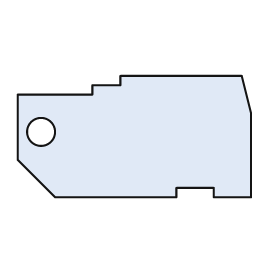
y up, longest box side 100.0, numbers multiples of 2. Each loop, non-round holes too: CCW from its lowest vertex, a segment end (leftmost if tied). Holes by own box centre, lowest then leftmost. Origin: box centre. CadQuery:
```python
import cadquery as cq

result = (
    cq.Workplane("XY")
    .moveTo(-34.0, -26.0)
    .lineTo(18.0, -26.0)
    .lineTo(18.0, -22.0)
    .lineTo(34.0, -22.0)
    .lineTo(34.0, -26.0)
    .lineTo(50.0, -26.0)
    .lineTo(50.0, 10.0)
    .lineTo(46.0, 26.0)
    .lineTo(-6.0, 26.0)
    .lineTo(-6.0, 22.0)
    .lineTo(-18.0, 22.0)
    .lineTo(-18.0, 18.0)
    .lineTo(-50.0, 18.0)
    .lineTo(-50.0, -10.0)
    .close()
    .moveTo(-40.0, 2.0)
    .circle(6.0)
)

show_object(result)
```